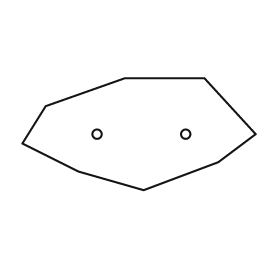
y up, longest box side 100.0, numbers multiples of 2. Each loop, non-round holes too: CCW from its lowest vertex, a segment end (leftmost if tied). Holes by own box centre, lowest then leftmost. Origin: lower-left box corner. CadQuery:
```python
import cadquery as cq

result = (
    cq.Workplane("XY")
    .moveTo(52.0, 0.0)
    .lineTo(84.0, 12.0)
    .lineTo(100.0, 24.0)
    .lineTo(78.0, 48.0)
    .lineTo(44.0, 48.0)
    .lineTo(10.0, 36.0)
    .lineTo(0.0, 20.0)
    .lineTo(24.0, 8.0)
    .close()
    .moveTo(32.0, 24.0)
    .circle(2.0)
    .moveTo(70.0, 24.0)
    .circle(2.0)
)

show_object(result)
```